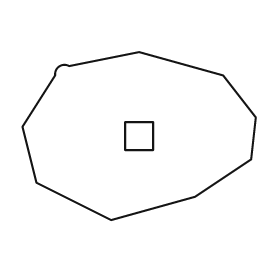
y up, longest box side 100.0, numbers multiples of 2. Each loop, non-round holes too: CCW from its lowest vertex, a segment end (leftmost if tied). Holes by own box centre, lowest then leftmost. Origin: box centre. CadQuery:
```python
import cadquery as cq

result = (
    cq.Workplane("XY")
    .moveTo(-12.0, -36.0)
    .lineTo(24.0, -26.0)
    .lineTo(48.0, -10.0)
    .lineTo(50.0, 8.0)
    .lineTo(36.0, 26.0)
    .lineTo(0.0, 36.0)
    .lineTo(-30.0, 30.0)
    .threePointArc((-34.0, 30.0), (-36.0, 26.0))
    .lineTo(-50.0, 4.0)
    .lineTo(-44.0, -20.0)
    .close()
    .moveTo(-6.0, -6.0)
    .lineTo(6.0, -6.0)
    .lineTo(6.0, 6.0)
    .lineTo(-6.0, 6.0)
    .close()
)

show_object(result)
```